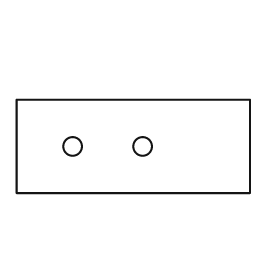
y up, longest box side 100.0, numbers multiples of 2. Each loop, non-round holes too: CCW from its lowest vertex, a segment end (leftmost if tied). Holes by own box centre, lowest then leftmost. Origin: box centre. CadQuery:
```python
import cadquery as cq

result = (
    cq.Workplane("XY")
    .moveTo(-50.0, -20.0)
    .lineTo(50.0, -20.0)
    .lineTo(50.0, 20.0)
    .lineTo(-50.0, 20.0)
    .close()
    .moveTo(-26.0, 0.0)
    .circle(4.0)
    .moveTo(4.0, 0.0)
    .circle(4.0)
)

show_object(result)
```